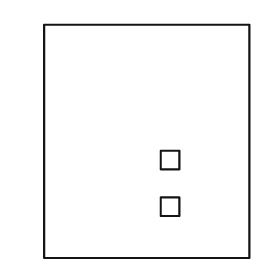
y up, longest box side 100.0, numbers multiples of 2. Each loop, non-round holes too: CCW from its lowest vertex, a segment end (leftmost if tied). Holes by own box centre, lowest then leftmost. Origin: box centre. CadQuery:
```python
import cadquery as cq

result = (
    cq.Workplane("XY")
    .moveTo(-44.0, -50.0)
    .lineTo(44.0, -50.0)
    .lineTo(44.0, 50.0)
    .lineTo(-44.0, 50.0)
    .close()
    .moveTo(6.0, -32.0)
    .lineTo(14.0, -32.0)
    .lineTo(14.0, -24.0)
    .lineTo(6.0, -24.0)
    .close()
    .moveTo(6.0, -12.0)
    .lineTo(14.0, -12.0)
    .lineTo(14.0, -4.0)
    .lineTo(6.0, -4.0)
    .close()
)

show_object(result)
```